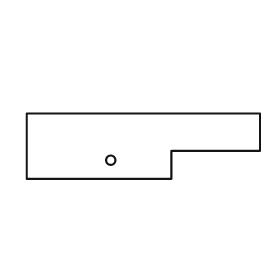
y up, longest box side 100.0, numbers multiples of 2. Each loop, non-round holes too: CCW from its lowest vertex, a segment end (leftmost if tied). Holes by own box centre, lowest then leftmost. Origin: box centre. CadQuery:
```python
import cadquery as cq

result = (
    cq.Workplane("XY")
    .moveTo(-50.0, -14.0)
    .lineTo(12.0, -14.0)
    .lineTo(12.0, -2.0)
    .lineTo(50.0, -2.0)
    .lineTo(50.0, 14.0)
    .lineTo(-50.0, 14.0)
    .close()
    .moveTo(-14.0, -6.0)
    .circle(2.0)
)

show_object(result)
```